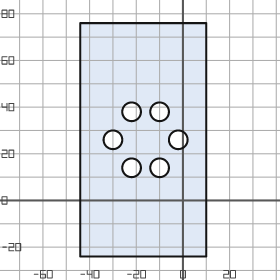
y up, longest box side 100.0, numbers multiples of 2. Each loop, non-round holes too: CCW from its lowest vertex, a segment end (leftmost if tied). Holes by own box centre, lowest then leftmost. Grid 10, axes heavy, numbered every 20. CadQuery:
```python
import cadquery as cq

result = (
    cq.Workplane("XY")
    .moveTo(-44.0, -24.0)
    .lineTo(10.0, -24.0)
    .lineTo(10.0, 76.0)
    .lineTo(-44.0, 76.0)
    .close()
    .moveTo(-22.0, 14.0)
    .circle(4.0)
    .moveTo(-10.0, 14.0)
    .circle(4.0)
    .moveTo(-30.0, 26.0)
    .circle(4.0)
    .moveTo(-2.0, 26.0)
    .circle(4.0)
    .moveTo(-22.0, 38.0)
    .circle(4.0)
    .moveTo(-10.0, 38.0)
    .circle(4.0)
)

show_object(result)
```